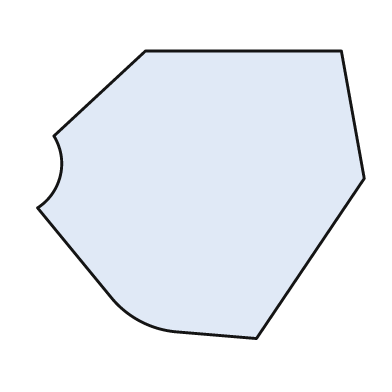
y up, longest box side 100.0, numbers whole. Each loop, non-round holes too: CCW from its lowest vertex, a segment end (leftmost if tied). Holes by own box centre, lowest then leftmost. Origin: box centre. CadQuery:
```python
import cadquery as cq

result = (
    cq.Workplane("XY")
    .moveTo(17.0, -44.0)
    .lineTo(50.0, 5.0)
    .lineTo(43.0, 44.0)
    .lineTo(-17.0, 44.0)
    .lineTo(-45.0, 18.0)
    .threePointArc((-43.0, 6.0), (-50.0, -4.0))
    .lineTo(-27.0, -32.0)
    .threePointArc((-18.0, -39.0), (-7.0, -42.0))
    .close()
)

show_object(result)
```